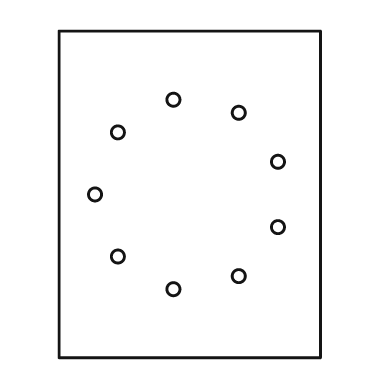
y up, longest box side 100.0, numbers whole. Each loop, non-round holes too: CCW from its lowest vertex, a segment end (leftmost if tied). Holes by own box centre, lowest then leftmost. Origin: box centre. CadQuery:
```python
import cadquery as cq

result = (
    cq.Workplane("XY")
    .moveTo(-40.0, -50.0)
    .lineTo(40.0, -50.0)
    .lineTo(40.0, 50.0)
    .lineTo(-40.0, 50.0)
    .close()
    .moveTo(-5.0, -29.0)
    .circle(2.0)
    .moveTo(15.0, -25.0)
    .circle(2.0)
    .moveTo(-22.0, -19.0)
    .circle(2.0)
    .moveTo(27.0, -10.0)
    .circle(2.0)
    .moveTo(-29.0, 0.0)
    .circle(2.0)
    .moveTo(27.0, 10.0)
    .circle(2.0)
    .moveTo(-22.0, 19.0)
    .circle(2.0)
    .moveTo(15.0, 25.0)
    .circle(2.0)
    .moveTo(-5.0, 29.0)
    .circle(2.0)
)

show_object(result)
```